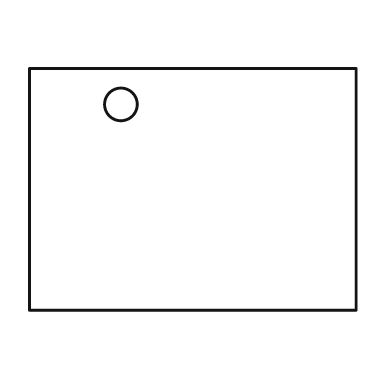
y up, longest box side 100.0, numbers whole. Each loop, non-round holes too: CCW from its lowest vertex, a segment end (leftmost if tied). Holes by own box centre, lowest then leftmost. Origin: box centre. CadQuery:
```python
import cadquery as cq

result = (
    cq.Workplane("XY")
    .moveTo(-50.0, -37.0)
    .lineTo(50.0, -37.0)
    .lineTo(50.0, 37.0)
    .lineTo(-50.0, 37.0)
    .close()
    .moveTo(-22.0, 26.0)
    .circle(5.0)
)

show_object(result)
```